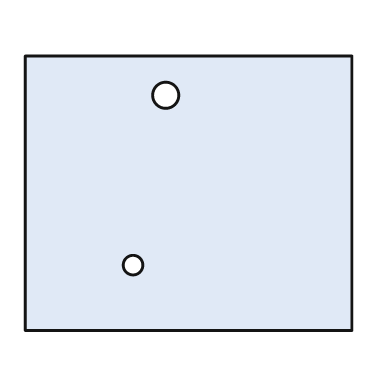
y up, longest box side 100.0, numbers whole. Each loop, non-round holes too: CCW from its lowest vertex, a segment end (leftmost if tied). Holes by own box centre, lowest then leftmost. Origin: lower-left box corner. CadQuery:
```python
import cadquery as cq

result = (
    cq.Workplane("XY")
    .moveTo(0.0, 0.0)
    .lineTo(100.0, 0.0)
    .lineTo(100.0, 84.0)
    .lineTo(0.0, 84.0)
    .close()
    .moveTo(33.0, 20.0)
    .circle(3.0)
    .moveTo(43.0, 72.0)
    .circle(4.0)
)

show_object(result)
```